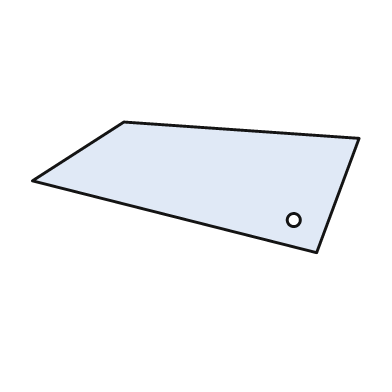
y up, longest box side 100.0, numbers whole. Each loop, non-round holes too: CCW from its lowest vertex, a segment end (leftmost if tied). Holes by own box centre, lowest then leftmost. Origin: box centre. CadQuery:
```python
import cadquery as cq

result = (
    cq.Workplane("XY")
    .moveTo(37.0, -20.0)
    .lineTo(50.0, 15.0)
    .lineTo(-22.0, 20.0)
    .lineTo(-50.0, 2.0)
    .close()
    .moveTo(30.0, -10.0)
    .circle(2.0)
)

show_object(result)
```